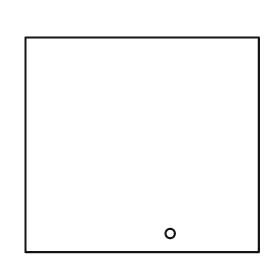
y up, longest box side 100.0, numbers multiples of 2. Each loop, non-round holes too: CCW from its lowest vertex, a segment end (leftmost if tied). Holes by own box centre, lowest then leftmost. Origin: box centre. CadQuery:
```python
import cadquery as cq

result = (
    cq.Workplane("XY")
    .moveTo(-50.0, -46.0)
    .lineTo(50.0, -46.0)
    .lineTo(50.0, 46.0)
    .lineTo(-50.0, 46.0)
    .close()
    .moveTo(12.0, -38.0)
    .circle(2.0)
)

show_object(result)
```